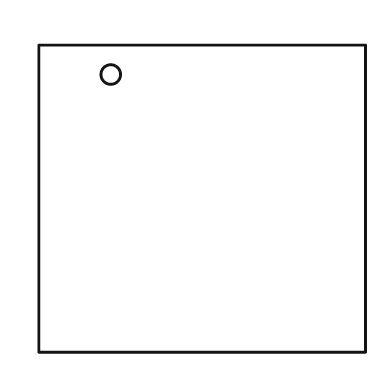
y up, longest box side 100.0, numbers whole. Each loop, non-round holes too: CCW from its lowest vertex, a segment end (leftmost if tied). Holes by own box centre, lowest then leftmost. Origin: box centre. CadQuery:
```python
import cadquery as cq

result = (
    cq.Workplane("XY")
    .moveTo(-50.0, -47.0)
    .lineTo(50.0, -47.0)
    .lineTo(50.0, 47.0)
    .lineTo(-50.0, 47.0)
    .close()
    .moveTo(-28.0, 38.0)
    .circle(3.0)
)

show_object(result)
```